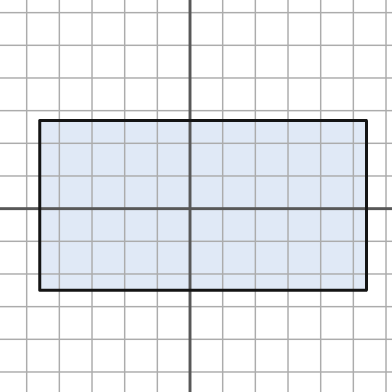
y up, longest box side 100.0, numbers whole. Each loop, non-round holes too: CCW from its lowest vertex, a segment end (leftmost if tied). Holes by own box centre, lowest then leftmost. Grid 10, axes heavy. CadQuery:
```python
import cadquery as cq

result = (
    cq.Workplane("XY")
    .moveTo(-46.0, -25.0)
    .lineTo(54.0, -25.0)
    .lineTo(54.0, 27.0)
    .lineTo(-46.0, 27.0)
    .close()
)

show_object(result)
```